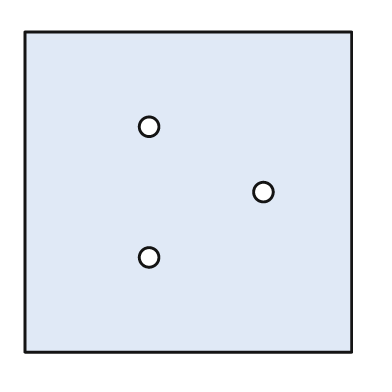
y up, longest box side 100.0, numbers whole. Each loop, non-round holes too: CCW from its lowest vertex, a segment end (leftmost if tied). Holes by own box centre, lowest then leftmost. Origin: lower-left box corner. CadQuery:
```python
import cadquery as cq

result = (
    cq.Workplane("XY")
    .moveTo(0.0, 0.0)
    .lineTo(100.0, 0.0)
    .lineTo(100.0, 98.0)
    .lineTo(0.0, 98.0)
    .close()
    .moveTo(38.0, 29.0)
    .circle(3.0)
    .moveTo(73.0, 49.0)
    .circle(3.0)
    .moveTo(38.0, 69.0)
    .circle(3.0)
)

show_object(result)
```